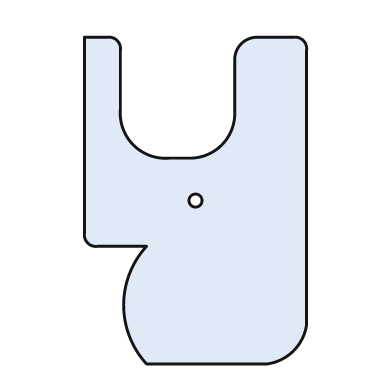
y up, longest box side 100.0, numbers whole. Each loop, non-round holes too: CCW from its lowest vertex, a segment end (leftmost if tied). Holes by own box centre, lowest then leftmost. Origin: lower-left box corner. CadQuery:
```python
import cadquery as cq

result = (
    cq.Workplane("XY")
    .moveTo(19.0, 0.0)
    .lineTo(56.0, 0.0)
    .threePointArc((64.0, 4.0), (68.0, 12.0))
    .lineTo(68.0, 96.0)
    .threePointArc((67.0, 99.0), (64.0, 100.0))
    .lineTo(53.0, 100.0)
    .threePointArc((48.0, 98.0), (46.0, 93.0))
    .lineTo(46.0, 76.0)
    .threePointArc((42.0, 67.0), (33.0, 63.0))
    .lineTo(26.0, 63.0)
    .threePointArc((15.0, 67.0), (11.0, 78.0))
    .lineTo(11.0, 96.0)
    .threePointArc((10.0, 99.0), (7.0, 100.0))
    .lineTo(0.0, 100.0)
    .lineTo(0.0, 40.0)
    .threePointArc((1.0, 37.0), (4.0, 36.0))
    .lineTo(19.0, 36.0)
    .threePointArc((12.0, 18.0), (19.0, 0.0))
    .close()
    .moveTo(34.0, 50.0)
    .circle(2.0)
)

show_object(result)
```